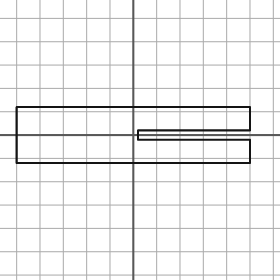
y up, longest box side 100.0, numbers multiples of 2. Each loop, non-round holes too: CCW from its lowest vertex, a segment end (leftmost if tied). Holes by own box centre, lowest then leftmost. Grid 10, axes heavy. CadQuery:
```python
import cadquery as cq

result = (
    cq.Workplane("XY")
    .moveTo(-50.0, -12.0)
    .lineTo(50.0, -12.0)
    .lineTo(50.0, -2.0)
    .lineTo(2.0, -2.0)
    .lineTo(2.0, 2.0)
    .lineTo(50.0, 2.0)
    .lineTo(50.0, 12.0)
    .lineTo(-50.0, 12.0)
    .close()
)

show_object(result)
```